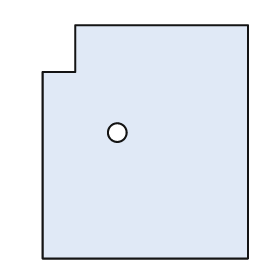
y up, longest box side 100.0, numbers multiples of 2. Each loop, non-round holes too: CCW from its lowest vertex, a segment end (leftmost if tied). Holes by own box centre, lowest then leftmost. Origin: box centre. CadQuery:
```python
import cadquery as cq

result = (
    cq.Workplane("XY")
    .moveTo(-44.0, -50.0)
    .lineTo(44.0, -50.0)
    .lineTo(44.0, 50.0)
    .lineTo(-30.0, 50.0)
    .lineTo(-30.0, 30.0)
    .lineTo(-44.0, 30.0)
    .close()
    .moveTo(-12.0, 4.0)
    .circle(4.0)
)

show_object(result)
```